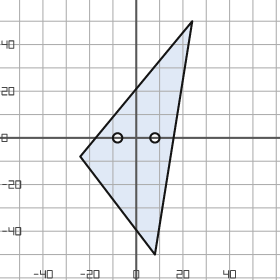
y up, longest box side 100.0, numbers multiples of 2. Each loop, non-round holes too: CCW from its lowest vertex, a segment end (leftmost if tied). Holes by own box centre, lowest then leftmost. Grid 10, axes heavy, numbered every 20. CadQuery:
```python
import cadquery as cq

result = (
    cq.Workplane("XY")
    .moveTo(8.0, -50.0)
    .lineTo(24.0, 50.0)
    .lineTo(-24.0, -8.0)
    .close()
    .moveTo(-8.0, 0.0)
    .circle(2.0)
    .moveTo(8.0, 0.0)
    .circle(2.0)
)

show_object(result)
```